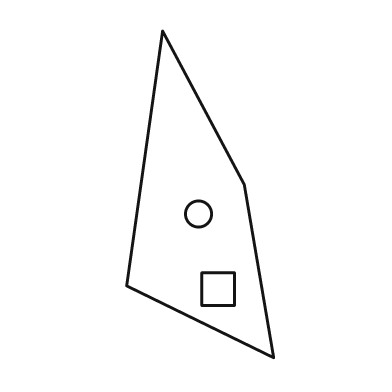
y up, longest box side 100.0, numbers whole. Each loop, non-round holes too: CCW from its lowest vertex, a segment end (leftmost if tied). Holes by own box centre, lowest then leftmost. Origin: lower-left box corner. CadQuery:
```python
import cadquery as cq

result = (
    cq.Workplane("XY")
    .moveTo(45.0, 0.0)
    .lineTo(36.0, 53.0)
    .lineTo(11.0, 100.0)
    .lineTo(0.0, 22.0)
    .close()
    .moveTo(23.0, 16.0)
    .lineTo(33.0, 16.0)
    .lineTo(33.0, 26.0)
    .lineTo(23.0, 26.0)
    .close()
    .moveTo(22.0, 44.0)
    .circle(4.0)
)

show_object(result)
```